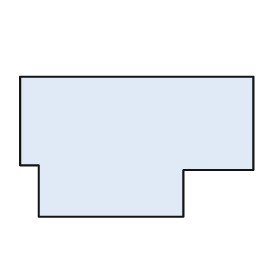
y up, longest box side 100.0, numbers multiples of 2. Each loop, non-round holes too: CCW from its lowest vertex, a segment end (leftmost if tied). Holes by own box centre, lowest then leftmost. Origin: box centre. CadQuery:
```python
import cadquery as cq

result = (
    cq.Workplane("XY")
    .moveTo(-42.0, -30.0)
    .lineTo(20.0, -30.0)
    .lineTo(20.0, -10.0)
    .lineTo(50.0, -10.0)
    .lineTo(50.0, 30.0)
    .lineTo(-50.0, 30.0)
    .lineTo(-50.0, -8.0)
    .lineTo(-42.0, -8.0)
    .close()
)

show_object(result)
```